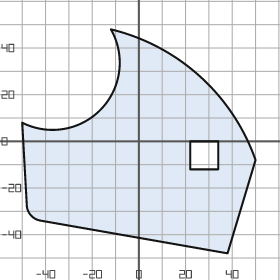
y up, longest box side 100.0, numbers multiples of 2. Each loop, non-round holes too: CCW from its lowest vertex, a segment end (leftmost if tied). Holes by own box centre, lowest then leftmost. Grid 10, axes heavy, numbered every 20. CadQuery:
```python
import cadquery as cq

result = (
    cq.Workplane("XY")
    .moveTo(38.0, -48.0)
    .lineTo(50.0, -8.0)
    .threePointArc((26.0, 28.0), (-12.0, 48.0))
    .threePointArc((-16.0, 14.0), (-50.0, 8.0))
    .lineTo(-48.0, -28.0)
    .threePointArc((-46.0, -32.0), (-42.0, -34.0))
    .close()
    .moveTo(22.0, -12.0)
    .lineTo(34.0, -12.0)
    .lineTo(34.0, 0.0)
    .lineTo(22.0, 0.0)
    .close()
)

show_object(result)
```